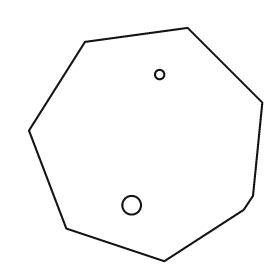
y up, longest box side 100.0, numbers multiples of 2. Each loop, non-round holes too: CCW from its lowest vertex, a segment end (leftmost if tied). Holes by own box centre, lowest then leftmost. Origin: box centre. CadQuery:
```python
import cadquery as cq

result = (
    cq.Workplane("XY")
    .moveTo(8.0, -50.0)
    .lineTo(42.0, -28.0)
    .lineTo(46.0, -22.0)
    .lineTo(50.0, 18.0)
    .lineTo(18.0, 50.0)
    .lineTo(-26.0, 44.0)
    .lineTo(-50.0, 6.0)
    .lineTo(-34.0, -36.0)
    .close()
    .moveTo(-6.0, -26.0)
    .circle(4.0)
    .moveTo(6.0, 30.0)
    .circle(2.0)
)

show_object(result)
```